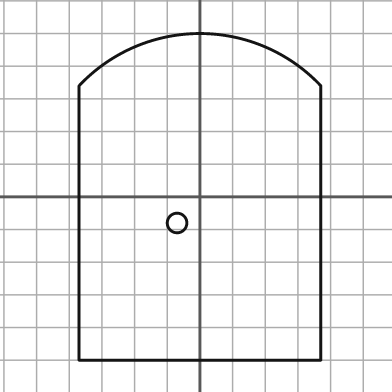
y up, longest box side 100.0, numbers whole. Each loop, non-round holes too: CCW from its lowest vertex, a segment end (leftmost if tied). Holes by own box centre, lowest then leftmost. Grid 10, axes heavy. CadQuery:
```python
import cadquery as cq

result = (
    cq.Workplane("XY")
    .moveTo(-37.0, -50.0)
    .lineTo(37.0, -50.0)
    .lineTo(37.0, 34.0)
    .threePointArc((0.0, 50.0), (-37.0, 34.0))
    .close()
    .moveTo(-7.0, -8.0)
    .circle(3.0)
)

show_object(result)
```